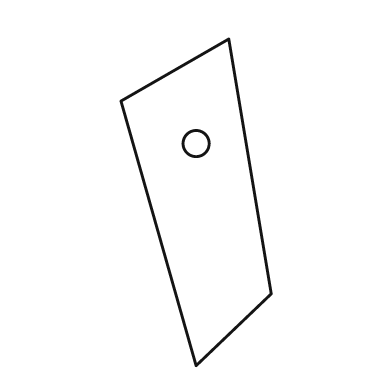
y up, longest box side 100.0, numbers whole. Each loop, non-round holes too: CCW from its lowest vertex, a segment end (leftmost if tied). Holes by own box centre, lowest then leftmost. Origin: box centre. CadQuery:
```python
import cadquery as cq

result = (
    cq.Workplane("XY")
    .moveTo(0.0, -50.0)
    .lineTo(23.0, -28.0)
    .lineTo(10.0, 50.0)
    .lineTo(-23.0, 31.0)
    .close()
    .moveTo(0.0, 18.0)
    .circle(4.0)
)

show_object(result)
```